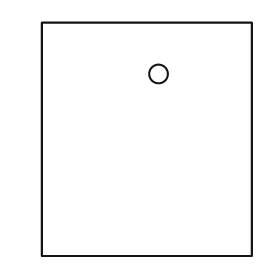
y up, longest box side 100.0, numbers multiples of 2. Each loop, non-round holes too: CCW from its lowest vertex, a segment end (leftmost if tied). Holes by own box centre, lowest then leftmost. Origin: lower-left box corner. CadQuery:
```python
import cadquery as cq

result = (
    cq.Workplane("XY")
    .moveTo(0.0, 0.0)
    .lineTo(90.0, 0.0)
    .lineTo(90.0, 100.0)
    .lineTo(0.0, 100.0)
    .close()
    .moveTo(50.0, 78.0)
    .circle(4.0)
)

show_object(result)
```